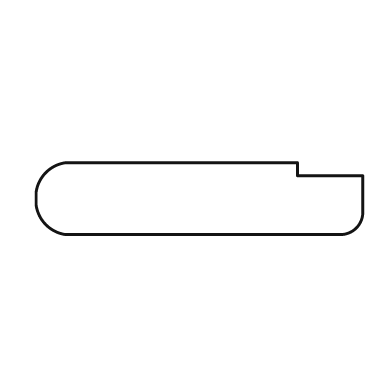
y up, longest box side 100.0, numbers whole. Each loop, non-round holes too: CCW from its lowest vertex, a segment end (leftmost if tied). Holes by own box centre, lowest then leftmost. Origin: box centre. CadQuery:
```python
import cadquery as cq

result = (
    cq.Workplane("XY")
    .moveTo(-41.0, -11.0)
    .lineTo(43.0, -11.0)
    .threePointArc((48.0, -9.0), (50.0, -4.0))
    .lineTo(50.0, 7.0)
    .lineTo(30.0, 7.0)
    .lineTo(30.0, 11.0)
    .lineTo(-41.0, 11.0)
    .threePointArc((-47.0, 8.0), (-50.0, 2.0))
    .lineTo(-50.0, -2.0)
    .threePointArc((-47.0, -8.0), (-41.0, -11.0))
    .close()
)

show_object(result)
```